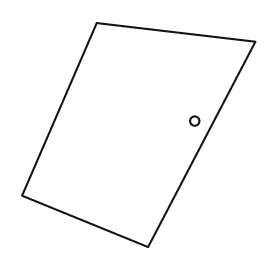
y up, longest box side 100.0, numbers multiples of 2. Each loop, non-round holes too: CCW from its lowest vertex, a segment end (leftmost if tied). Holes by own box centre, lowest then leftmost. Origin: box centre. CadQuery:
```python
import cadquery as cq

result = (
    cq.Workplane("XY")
    .moveTo(4.0, -48.0)
    .lineTo(50.0, 40.0)
    .lineTo(-18.0, 48.0)
    .lineTo(-50.0, -26.0)
    .close()
    .moveTo(24.0, 6.0)
    .circle(2.0)
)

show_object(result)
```